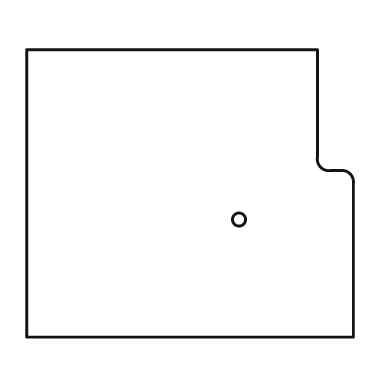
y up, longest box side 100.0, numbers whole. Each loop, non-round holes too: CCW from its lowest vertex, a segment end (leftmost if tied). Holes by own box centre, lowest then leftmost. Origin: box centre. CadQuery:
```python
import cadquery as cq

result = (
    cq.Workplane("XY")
    .moveTo(-50.0, -44.0)
    .lineTo(50.0, -44.0)
    .lineTo(50.0, 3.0)
    .threePointArc((49.0, 6.0), (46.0, 7.0))
    .lineTo(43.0, 7.0)
    .threePointArc((40.0, 8.0), (39.0, 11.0))
    .lineTo(39.0, 44.0)
    .lineTo(-50.0, 44.0)
    .close()
    .moveTo(15.0, -8.0)
    .circle(2.0)
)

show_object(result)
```